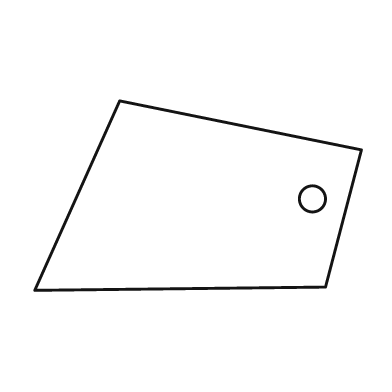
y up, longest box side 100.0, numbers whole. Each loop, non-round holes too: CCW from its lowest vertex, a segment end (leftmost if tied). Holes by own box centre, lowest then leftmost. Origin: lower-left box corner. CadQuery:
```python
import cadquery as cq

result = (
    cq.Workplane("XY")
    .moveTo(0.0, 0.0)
    .lineTo(89.0, 1.0)
    .lineTo(100.0, 43.0)
    .lineTo(26.0, 58.0)
    .close()
    .moveTo(85.0, 28.0)
    .circle(4.0)
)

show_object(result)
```